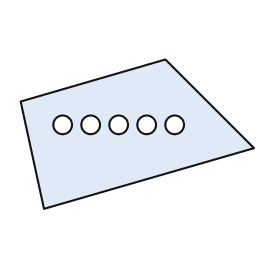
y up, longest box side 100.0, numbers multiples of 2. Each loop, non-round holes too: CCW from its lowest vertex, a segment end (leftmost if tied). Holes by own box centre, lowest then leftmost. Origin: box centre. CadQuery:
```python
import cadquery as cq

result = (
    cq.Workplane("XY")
    .moveTo(-40.0, -32.0)
    .lineTo(50.0, -6.0)
    .lineTo(12.0, 32.0)
    .lineTo(-50.0, 14.0)
    .close()
    .moveTo(-32.0, 4.0)
    .circle(4.0)
    .moveTo(-20.0, 4.0)
    .circle(4.0)
    .moveTo(-8.0, 4.0)
    .circle(4.0)
    .moveTo(4.0, 4.0)
    .circle(4.0)
    .moveTo(16.0, 4.0)
    .circle(4.0)
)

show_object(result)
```